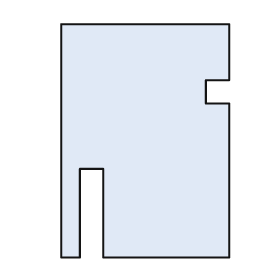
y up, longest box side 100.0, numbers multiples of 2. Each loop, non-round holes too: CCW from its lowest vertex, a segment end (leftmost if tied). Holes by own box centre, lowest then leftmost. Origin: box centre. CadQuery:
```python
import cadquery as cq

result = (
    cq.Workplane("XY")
    .moveTo(-36.0, -50.0)
    .lineTo(-28.0, -50.0)
    .lineTo(-28.0, -12.0)
    .lineTo(-18.0, -12.0)
    .lineTo(-18.0, -50.0)
    .lineTo(36.0, -50.0)
    .lineTo(36.0, 16.0)
    .lineTo(26.0, 16.0)
    .lineTo(26.0, 26.0)
    .lineTo(36.0, 26.0)
    .lineTo(36.0, 50.0)
    .lineTo(-36.0, 50.0)
    .close()
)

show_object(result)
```